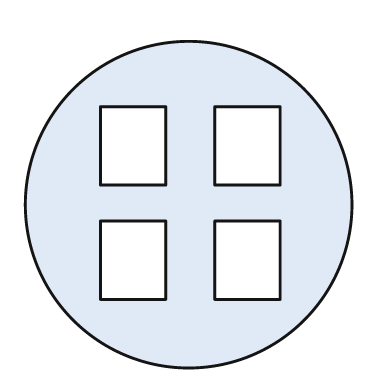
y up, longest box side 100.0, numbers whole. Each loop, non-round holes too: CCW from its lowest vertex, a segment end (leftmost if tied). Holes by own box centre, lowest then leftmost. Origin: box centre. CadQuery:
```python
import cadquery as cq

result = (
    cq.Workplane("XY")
    .moveTo(0.0, 0.0)
    .circle(50.0)
    .moveTo(-27.0, -29.0)
    .lineTo(-7.0, -29.0)
    .lineTo(-7.0, -5.0)
    .lineTo(-27.0, -5.0)
    .close()
    .moveTo(8.0, -29.0)
    .lineTo(28.0, -29.0)
    .lineTo(28.0, -5.0)
    .lineTo(8.0, -5.0)
    .close()
    .moveTo(-27.0, 6.0)
    .lineTo(-7.0, 6.0)
    .lineTo(-7.0, 30.0)
    .lineTo(-27.0, 30.0)
    .close()
    .moveTo(8.0, 6.0)
    .lineTo(28.0, 6.0)
    .lineTo(28.0, 30.0)
    .lineTo(8.0, 30.0)
    .close()
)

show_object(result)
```